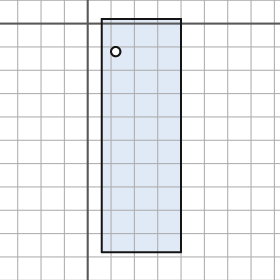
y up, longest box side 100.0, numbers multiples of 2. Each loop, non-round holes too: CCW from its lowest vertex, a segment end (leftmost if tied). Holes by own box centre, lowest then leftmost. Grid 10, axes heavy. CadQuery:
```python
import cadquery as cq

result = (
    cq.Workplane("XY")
    .moveTo(6.0, -98.0)
    .lineTo(40.0, -98.0)
    .lineTo(40.0, 2.0)
    .lineTo(6.0, 2.0)
    .close()
    .moveTo(12.0, -12.0)
    .circle(2.0)
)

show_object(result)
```